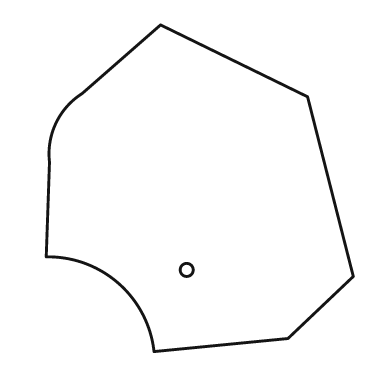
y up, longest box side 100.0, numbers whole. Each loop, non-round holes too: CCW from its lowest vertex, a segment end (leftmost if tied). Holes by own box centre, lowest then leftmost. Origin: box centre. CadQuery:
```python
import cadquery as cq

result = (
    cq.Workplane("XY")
    .moveTo(-14.0, -50.0)
    .lineTo(27.0, -46.0)
    .lineTo(47.0, -27.0)
    .lineTo(33.0, 28.0)
    .lineTo(-12.0, 50.0)
    .lineTo(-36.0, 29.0)
    .threePointArc((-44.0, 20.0), (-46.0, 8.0))
    .lineTo(-47.0, -21.0)
    .threePointArc((-25.0, -29.0), (-14.0, -50.0))
    .close()
    .moveTo(-4.0, -25.0)
    .circle(2.0)
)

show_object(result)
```